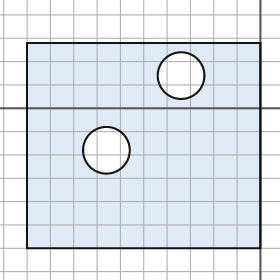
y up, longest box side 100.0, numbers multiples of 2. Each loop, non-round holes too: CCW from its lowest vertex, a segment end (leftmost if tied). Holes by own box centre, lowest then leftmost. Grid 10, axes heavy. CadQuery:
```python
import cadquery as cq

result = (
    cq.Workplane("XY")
    .moveTo(-100.0, -60.0)
    .lineTo(0.0, -60.0)
    .lineTo(0.0, 28.0)
    .lineTo(-100.0, 28.0)
    .close()
    .moveTo(-66.0, -18.0)
    .circle(10.0)
    .moveTo(-34.0, 14.0)
    .circle(10.0)
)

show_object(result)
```